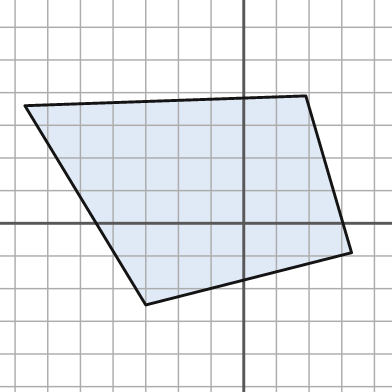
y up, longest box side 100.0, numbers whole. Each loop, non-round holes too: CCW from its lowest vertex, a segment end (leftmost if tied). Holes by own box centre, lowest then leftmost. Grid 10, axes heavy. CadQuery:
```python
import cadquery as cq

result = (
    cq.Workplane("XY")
    .moveTo(-30.0, -25.0)
    .lineTo(33.0, -9.0)
    .lineTo(19.0, 39.0)
    .lineTo(-67.0, 36.0)
    .close()
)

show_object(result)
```